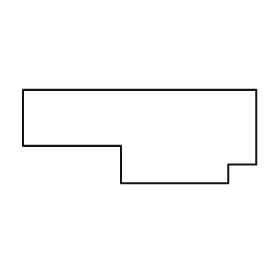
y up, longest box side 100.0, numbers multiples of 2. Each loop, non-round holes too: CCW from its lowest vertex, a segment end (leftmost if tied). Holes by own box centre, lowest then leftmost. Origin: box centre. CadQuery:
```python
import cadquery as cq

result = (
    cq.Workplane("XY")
    .moveTo(-8.0, -20.0)
    .lineTo(38.0, -20.0)
    .lineTo(38.0, -12.0)
    .lineTo(50.0, -12.0)
    .lineTo(50.0, 20.0)
    .lineTo(-50.0, 20.0)
    .lineTo(-50.0, -4.0)
    .lineTo(-8.0, -4.0)
    .close()
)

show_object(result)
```